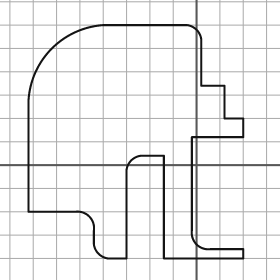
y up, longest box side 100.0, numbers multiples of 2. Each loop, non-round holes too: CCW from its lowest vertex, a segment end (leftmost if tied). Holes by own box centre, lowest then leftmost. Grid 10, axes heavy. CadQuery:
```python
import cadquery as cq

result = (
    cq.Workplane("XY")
    .moveTo(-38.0, -40.0)
    .lineTo(-30.0, -40.0)
    .lineTo(-30.0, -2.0)
    .threePointArc((-28.0, 2.0), (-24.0, 4.0))
    .lineTo(-14.0, 4.0)
    .lineTo(-14.0, -40.0)
    .lineTo(20.0, -40.0)
    .lineTo(20.0, -36.0)
    .lineTo(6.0, -36.0)
    .threePointArc((0.0, -34.0), (-2.0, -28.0))
    .lineTo(-2.0, 12.0)
    .lineTo(20.0, 12.0)
    .lineTo(20.0, 20.0)
    .lineTo(12.0, 20.0)
    .lineTo(12.0, 34.0)
    .lineTo(2.0, 34.0)
    .lineTo(2.0, 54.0)
    .threePointArc((0.0, 58.0), (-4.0, 60.0))
    .lineTo(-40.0, 60.0)
    .threePointArc((-62.0, 50.0), (-72.0, 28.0))
    .lineTo(-72.0, -20.0)
    .lineTo(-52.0, -20.0)
    .threePointArc((-46.0, -22.0), (-44.0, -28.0))
    .lineTo(-44.0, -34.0)
    .threePointArc((-42.0, -38.0), (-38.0, -40.0))
    .close()
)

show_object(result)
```